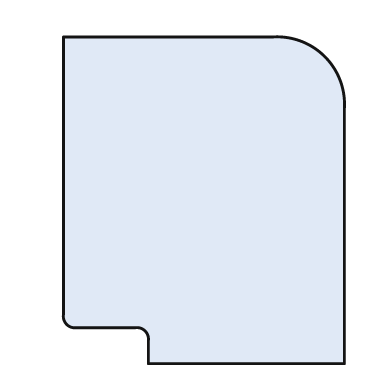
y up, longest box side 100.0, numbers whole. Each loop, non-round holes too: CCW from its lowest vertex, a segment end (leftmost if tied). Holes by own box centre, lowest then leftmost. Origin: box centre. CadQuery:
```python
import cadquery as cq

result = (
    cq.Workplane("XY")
    .moveTo(-17.0, -50.0)
    .lineTo(43.0, -50.0)
    .lineTo(43.0, 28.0)
    .threePointArc((37.0, 44.0), (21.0, 50.0))
    .lineTo(-43.0, 50.0)
    .lineTo(-43.0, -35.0)
    .threePointArc((-42.0, -38.0), (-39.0, -39.0))
    .lineTo(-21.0, -39.0)
    .threePointArc((-18.0, -40.0), (-17.0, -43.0))
    .close()
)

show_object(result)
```